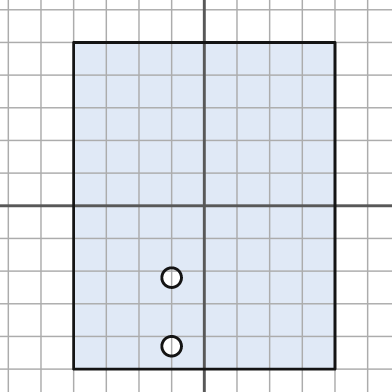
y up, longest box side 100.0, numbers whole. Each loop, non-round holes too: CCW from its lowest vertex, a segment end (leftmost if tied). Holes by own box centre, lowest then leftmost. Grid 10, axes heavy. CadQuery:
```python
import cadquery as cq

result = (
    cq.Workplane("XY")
    .moveTo(-40.0, -50.0)
    .lineTo(40.0, -50.0)
    .lineTo(40.0, 50.0)
    .lineTo(-40.0, 50.0)
    .close()
    .moveTo(-10.0, -43.0)
    .circle(3.0)
    .moveTo(-10.0, -22.0)
    .circle(3.0)
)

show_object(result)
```